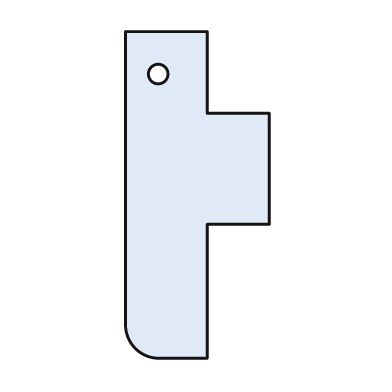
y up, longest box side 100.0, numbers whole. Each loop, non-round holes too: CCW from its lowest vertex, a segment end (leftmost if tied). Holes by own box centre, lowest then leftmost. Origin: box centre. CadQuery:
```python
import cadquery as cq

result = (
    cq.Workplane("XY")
    .moveTo(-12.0, -50.0)
    .lineTo(3.0, -50.0)
    .lineTo(3.0, -9.0)
    .lineTo(22.0, -9.0)
    .lineTo(22.0, 25.0)
    .lineTo(3.0, 25.0)
    .lineTo(3.0, 50.0)
    .lineTo(-22.0, 50.0)
    .lineTo(-22.0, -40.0)
    .threePointArc((-19.0, -47.0), (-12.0, -50.0))
    .close()
    .moveTo(-12.0, 37.0)
    .circle(3.0)
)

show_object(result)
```